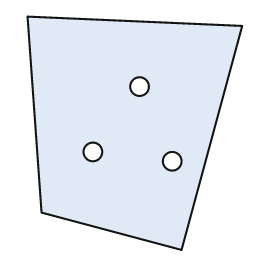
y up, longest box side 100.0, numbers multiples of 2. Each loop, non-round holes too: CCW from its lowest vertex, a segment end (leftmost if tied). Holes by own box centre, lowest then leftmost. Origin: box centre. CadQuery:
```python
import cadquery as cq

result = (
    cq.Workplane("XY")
    .moveTo(20.0, -50.0)
    .lineTo(46.0, 46.0)
    .lineTo(-46.0, 50.0)
    .lineTo(-40.0, -34.0)
    .close()
    .moveTo(16.0, -12.0)
    .circle(4.0)
    .moveTo(-18.0, -8.0)
    .circle(4.0)
    .moveTo(2.0, 20.0)
    .circle(4.0)
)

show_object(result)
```